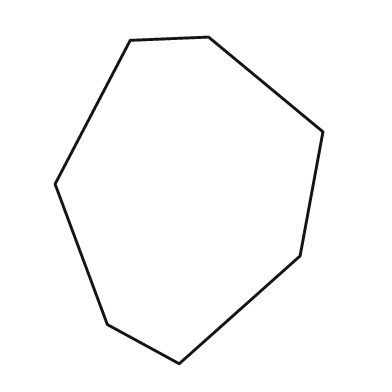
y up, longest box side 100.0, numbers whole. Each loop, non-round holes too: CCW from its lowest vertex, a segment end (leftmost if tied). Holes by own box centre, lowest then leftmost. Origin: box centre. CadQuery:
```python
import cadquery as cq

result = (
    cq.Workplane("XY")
    .moveTo(-3.0, -50.0)
    .lineTo(34.0, -17.0)
    .lineTo(41.0, 21.0)
    .lineTo(6.0, 50.0)
    .lineTo(-18.0, 49.0)
    .lineTo(-41.0, 5.0)
    .lineTo(-25.0, -38.0)
    .close()
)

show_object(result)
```